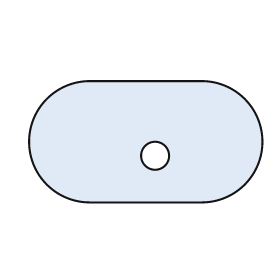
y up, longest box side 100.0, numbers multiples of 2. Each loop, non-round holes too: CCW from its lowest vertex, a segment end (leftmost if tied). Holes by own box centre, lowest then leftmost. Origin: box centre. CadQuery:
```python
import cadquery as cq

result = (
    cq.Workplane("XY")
    .moveTo(-24.0, -26.0)
    .lineTo(24.0, -26.0)
    .threePointArc((50.0, 0.0), (24.0, 26.0))
    .lineTo(-24.0, 26.0)
    .threePointArc((-50.0, 0.0), (-24.0, -26.0))
    .close()
    .moveTo(4.0, -6.0)
    .circle(6.0)
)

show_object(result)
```